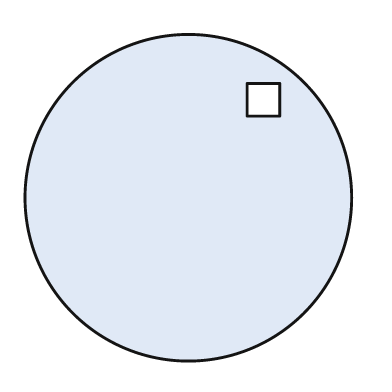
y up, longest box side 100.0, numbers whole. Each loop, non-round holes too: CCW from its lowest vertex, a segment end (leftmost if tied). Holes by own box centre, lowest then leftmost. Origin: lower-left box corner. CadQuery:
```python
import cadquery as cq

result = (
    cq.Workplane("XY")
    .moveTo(50.0, 50.0)
    .circle(50.0)
    .moveTo(68.0, 75.0)
    .lineTo(78.0, 75.0)
    .lineTo(78.0, 85.0)
    .lineTo(68.0, 85.0)
    .close()
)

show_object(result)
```